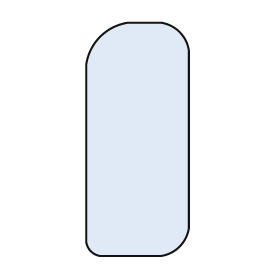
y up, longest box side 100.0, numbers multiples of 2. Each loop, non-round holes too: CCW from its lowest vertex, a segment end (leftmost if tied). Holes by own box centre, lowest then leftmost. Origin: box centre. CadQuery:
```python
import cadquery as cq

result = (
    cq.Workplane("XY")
    .moveTo(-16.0, -50.0)
    .lineTo(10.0, -50.0)
    .threePointArc((18.0, -46.0), (22.0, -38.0))
    .lineTo(22.0, 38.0)
    .threePointArc((18.0, 46.0), (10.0, 50.0))
    .lineTo(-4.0, 50.0)
    .threePointArc((-16.0, 44.0), (-22.0, 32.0))
    .lineTo(-22.0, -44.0)
    .threePointArc((-20.0, -48.0), (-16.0, -50.0))
    .close()
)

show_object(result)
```